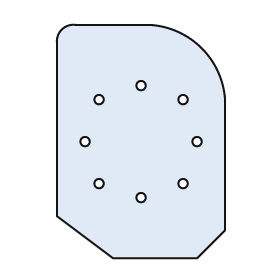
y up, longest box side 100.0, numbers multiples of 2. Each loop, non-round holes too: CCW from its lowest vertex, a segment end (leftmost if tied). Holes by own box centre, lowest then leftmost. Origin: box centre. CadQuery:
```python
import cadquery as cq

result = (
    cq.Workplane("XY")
    .moveTo(-12.0, -50.0)
    .lineTo(24.0, -50.0)
    .lineTo(36.0, -38.0)
    .lineTo(36.0, 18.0)
    .threePointArc((26.0, 40.0), (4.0, 50.0))
    .lineTo(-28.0, 50.0)
    .threePointArc((-34.0, 48.0), (-36.0, 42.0))
    .lineTo(-36.0, -32.0)
    .close()
    .moveTo(0.0, -24.0)
    .circle(2.0)
    .moveTo(-18.0, -18.0)
    .circle(2.0)
    .moveTo(18.0, -18.0)
    .circle(2.0)
    .moveTo(-24.0, 0.0)
    .circle(2.0)
    .moveTo(24.0, 0.0)
    .circle(2.0)
    .moveTo(-18.0, 18.0)
    .circle(2.0)
    .moveTo(18.0, 18.0)
    .circle(2.0)
    .moveTo(0.0, 24.0)
    .circle(2.0)
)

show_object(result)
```